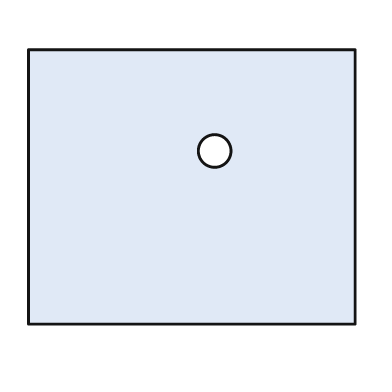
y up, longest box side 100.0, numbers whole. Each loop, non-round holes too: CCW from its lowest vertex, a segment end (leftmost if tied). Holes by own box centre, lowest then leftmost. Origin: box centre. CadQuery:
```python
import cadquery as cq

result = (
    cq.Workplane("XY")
    .moveTo(-50.0, -42.0)
    .lineTo(50.0, -42.0)
    .lineTo(50.0, 42.0)
    .lineTo(-50.0, 42.0)
    .close()
    .moveTo(7.0, 11.0)
    .circle(5.0)
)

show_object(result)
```